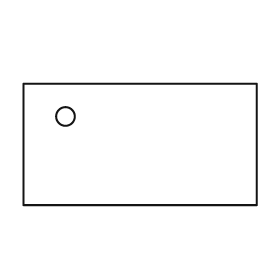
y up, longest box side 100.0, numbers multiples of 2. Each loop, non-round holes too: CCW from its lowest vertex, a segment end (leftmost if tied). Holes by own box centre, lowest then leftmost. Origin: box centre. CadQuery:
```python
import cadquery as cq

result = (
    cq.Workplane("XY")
    .moveTo(-50.0, -26.0)
    .lineTo(50.0, -26.0)
    .lineTo(50.0, 26.0)
    .lineTo(-50.0, 26.0)
    .close()
    .moveTo(-32.0, 12.0)
    .circle(4.0)
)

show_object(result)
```